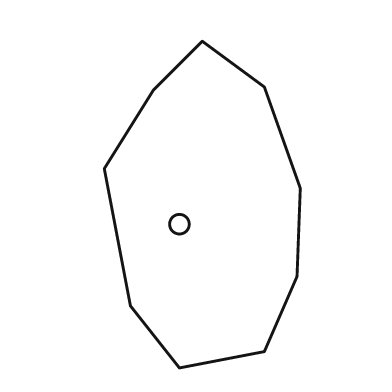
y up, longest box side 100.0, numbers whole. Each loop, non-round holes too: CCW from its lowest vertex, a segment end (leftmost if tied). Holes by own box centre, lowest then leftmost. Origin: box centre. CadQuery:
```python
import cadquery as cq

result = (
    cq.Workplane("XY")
    .moveTo(-7.0, -50.0)
    .lineTo(19.0, -45.0)
    .lineTo(29.0, -22.0)
    .lineTo(30.0, 5.0)
    .lineTo(19.0, 36.0)
    .lineTo(0.0, 50.0)
    .lineTo(-15.0, 35.0)
    .lineTo(-30.0, 11.0)
    .lineTo(-22.0, -31.0)
    .close()
    .moveTo(-7.0, -6.0)
    .circle(3.0)
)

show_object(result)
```